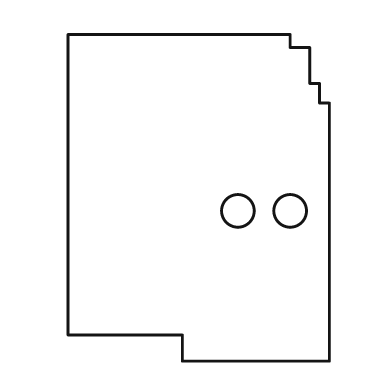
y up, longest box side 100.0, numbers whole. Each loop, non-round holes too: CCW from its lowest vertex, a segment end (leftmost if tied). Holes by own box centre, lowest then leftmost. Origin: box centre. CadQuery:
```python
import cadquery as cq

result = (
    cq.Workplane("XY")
    .moveTo(-5.0, -50.0)
    .lineTo(40.0, -50.0)
    .lineTo(40.0, 29.0)
    .lineTo(37.0, 29.0)
    .lineTo(37.0, 35.0)
    .lineTo(34.0, 35.0)
    .lineTo(34.0, 46.0)
    .lineTo(28.0, 46.0)
    .lineTo(28.0, 50.0)
    .lineTo(-40.0, 50.0)
    .lineTo(-40.0, -42.0)
    .lineTo(-5.0, -42.0)
    .close()
    .moveTo(12.0, -4.0)
    .circle(5.0)
    .moveTo(28.0, -4.0)
    .circle(5.0)
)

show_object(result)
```